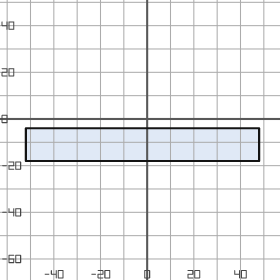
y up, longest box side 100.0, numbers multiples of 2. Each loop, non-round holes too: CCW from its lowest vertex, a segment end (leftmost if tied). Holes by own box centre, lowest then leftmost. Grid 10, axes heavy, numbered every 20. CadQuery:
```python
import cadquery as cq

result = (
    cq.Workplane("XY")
    .moveTo(-52.0, -18.0)
    .lineTo(48.0, -18.0)
    .lineTo(48.0, -4.0)
    .lineTo(-52.0, -4.0)
    .close()
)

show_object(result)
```